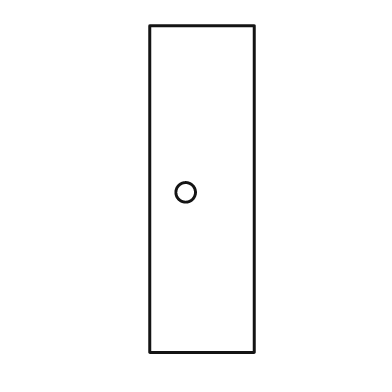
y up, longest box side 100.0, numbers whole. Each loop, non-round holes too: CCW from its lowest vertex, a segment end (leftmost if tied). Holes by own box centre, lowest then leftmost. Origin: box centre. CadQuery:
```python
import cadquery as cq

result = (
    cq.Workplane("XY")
    .moveTo(-16.0, -50.0)
    .lineTo(16.0, -50.0)
    .lineTo(16.0, 50.0)
    .lineTo(-16.0, 50.0)
    .close()
    .moveTo(-5.0, -1.0)
    .circle(3.0)
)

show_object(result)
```